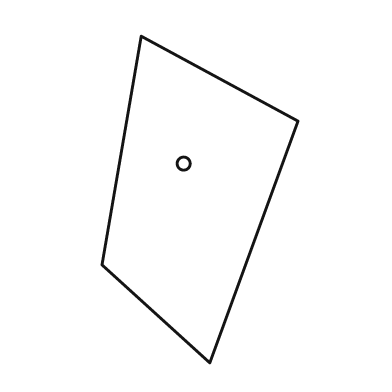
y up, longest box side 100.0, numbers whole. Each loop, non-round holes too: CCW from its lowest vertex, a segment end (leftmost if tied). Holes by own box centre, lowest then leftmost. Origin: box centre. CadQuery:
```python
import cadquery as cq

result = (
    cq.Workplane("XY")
    .moveTo(3.0, -50.0)
    .lineTo(30.0, 24.0)
    .lineTo(-18.0, 50.0)
    .lineTo(-30.0, -20.0)
    .close()
    .moveTo(-5.0, 11.0)
    .circle(2.0)
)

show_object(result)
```